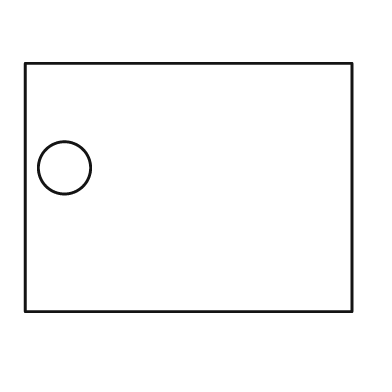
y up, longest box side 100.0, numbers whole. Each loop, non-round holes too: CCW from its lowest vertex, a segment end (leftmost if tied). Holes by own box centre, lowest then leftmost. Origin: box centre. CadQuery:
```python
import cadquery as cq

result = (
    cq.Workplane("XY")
    .moveTo(-50.0, -38.0)
    .lineTo(50.0, -38.0)
    .lineTo(50.0, 38.0)
    .lineTo(-50.0, 38.0)
    .close()
    .moveTo(-38.0, 6.0)
    .circle(8.0)
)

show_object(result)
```